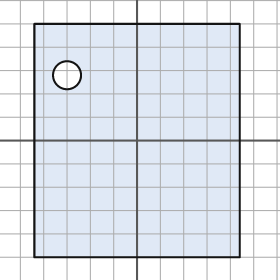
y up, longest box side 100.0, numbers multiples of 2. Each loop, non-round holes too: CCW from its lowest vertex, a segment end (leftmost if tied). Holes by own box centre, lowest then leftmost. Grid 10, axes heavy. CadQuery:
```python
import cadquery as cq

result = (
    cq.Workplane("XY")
    .moveTo(-44.0, -50.0)
    .lineTo(44.0, -50.0)
    .lineTo(44.0, 50.0)
    .lineTo(-44.0, 50.0)
    .close()
    .moveTo(-30.0, 28.0)
    .circle(6.0)
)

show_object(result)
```